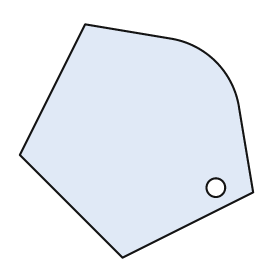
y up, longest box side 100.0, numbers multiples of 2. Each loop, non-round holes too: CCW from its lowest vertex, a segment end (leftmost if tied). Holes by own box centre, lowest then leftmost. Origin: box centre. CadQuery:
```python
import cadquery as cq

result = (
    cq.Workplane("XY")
    .moveTo(-6.0, -50.0)
    .lineTo(50.0, -22.0)
    .lineTo(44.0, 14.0)
    .threePointArc((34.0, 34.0), (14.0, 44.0))
    .lineTo(-22.0, 50.0)
    .lineTo(-50.0, -6.0)
    .close()
    .moveTo(34.0, -20.0)
    .circle(4.0)
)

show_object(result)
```